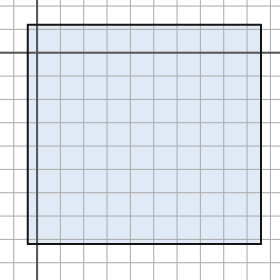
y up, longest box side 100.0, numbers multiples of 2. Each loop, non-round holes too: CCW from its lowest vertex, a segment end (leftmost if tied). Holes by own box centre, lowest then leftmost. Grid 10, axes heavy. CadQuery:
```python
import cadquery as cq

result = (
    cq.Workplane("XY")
    .moveTo(-4.0, -82.0)
    .lineTo(96.0, -82.0)
    .lineTo(96.0, 12.0)
    .lineTo(-4.0, 12.0)
    .close()
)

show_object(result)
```